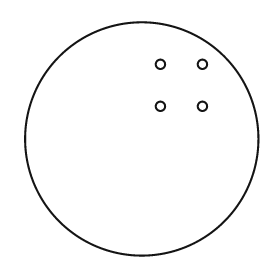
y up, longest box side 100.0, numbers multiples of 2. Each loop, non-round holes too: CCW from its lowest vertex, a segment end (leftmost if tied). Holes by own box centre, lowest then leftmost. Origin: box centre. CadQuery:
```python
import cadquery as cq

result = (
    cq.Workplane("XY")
    .moveTo(0.0, 0.0)
    .circle(50.0)
    .moveTo(8.0, 14.0)
    .circle(2.0)
    .moveTo(26.0, 14.0)
    .circle(2.0)
    .moveTo(8.0, 32.0)
    .circle(2.0)
    .moveTo(26.0, 32.0)
    .circle(2.0)
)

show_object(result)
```